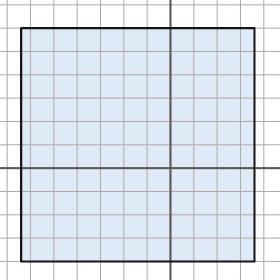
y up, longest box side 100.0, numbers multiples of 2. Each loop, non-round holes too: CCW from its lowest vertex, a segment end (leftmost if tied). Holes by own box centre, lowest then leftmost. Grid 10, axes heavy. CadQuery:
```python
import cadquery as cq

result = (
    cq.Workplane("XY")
    .moveTo(-64.0, -40.0)
    .lineTo(36.0, -40.0)
    .lineTo(36.0, 60.0)
    .lineTo(-64.0, 60.0)
    .close()
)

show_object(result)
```